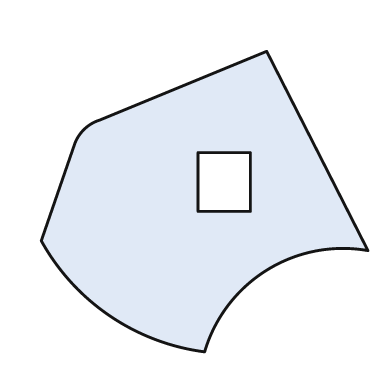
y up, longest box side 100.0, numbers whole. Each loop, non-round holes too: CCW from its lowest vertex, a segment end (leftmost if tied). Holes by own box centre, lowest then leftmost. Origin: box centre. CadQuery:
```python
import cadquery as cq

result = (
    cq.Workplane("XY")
    .moveTo(0.0, -46.0)
    .threePointArc((19.0, -21.0), (50.0, -15.0))
    .lineTo(19.0, 46.0)
    .lineTo(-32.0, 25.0)
    .threePointArc((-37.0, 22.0), (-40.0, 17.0))
    .lineTo(-50.0, -12.0)
    .threePointArc((-29.0, -35.0), (0.0, -46.0))
    .close()
    .moveTo(-2.0, -3.0)
    .lineTo(14.0, -3.0)
    .lineTo(14.0, 15.0)
    .lineTo(-2.0, 15.0)
    .close()
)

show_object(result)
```